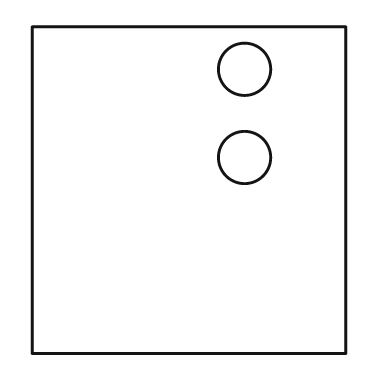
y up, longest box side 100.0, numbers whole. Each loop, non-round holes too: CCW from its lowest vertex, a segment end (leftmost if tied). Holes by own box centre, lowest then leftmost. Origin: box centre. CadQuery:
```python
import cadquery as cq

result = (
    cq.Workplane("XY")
    .moveTo(-48.0, -50.0)
    .lineTo(48.0, -50.0)
    .lineTo(48.0, 50.0)
    .lineTo(-48.0, 50.0)
    .close()
    .moveTo(17.0, 10.0)
    .circle(8.0)
    .moveTo(17.0, 37.0)
    .circle(8.0)
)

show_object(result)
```